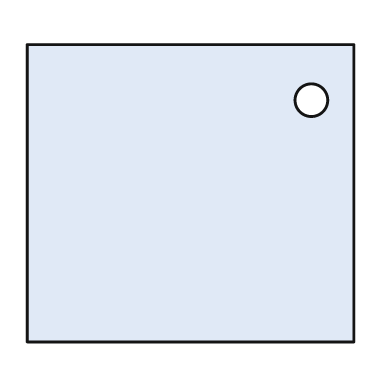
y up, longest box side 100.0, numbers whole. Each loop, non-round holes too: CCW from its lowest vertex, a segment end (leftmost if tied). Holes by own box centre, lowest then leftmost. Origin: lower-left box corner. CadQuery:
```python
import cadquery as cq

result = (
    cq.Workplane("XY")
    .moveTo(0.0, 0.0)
    .lineTo(100.0, 0.0)
    .lineTo(100.0, 91.0)
    .lineTo(0.0, 91.0)
    .close()
    .moveTo(87.0, 74.0)
    .circle(5.0)
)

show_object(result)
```